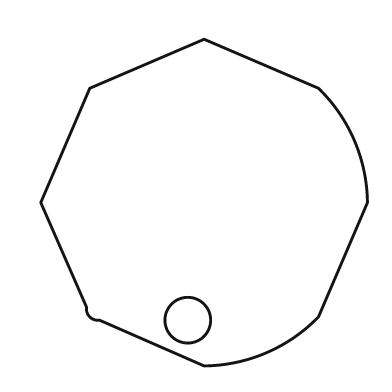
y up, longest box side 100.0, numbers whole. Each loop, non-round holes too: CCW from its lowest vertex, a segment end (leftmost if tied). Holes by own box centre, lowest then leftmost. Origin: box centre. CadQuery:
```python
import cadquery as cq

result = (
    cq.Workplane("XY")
    .moveTo(0.0, -50.0)
    .threePointArc((19.0, -46.0), (35.0, -35.0))
    .lineTo(50.0, 0.0)
    .threePointArc((46.0, 19.0), (35.0, 35.0))
    .lineTo(0.0, 50.0)
    .lineTo(-35.0, 35.0)
    .lineTo(-50.0, 0.0)
    .lineTo(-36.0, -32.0)
    .threePointArc((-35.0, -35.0), (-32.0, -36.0))
    .close()
    .moveTo(-5.0, -36.0)
    .circle(7.0)
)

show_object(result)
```